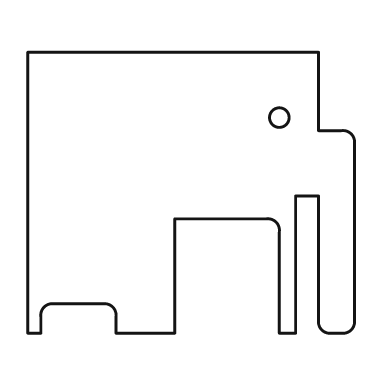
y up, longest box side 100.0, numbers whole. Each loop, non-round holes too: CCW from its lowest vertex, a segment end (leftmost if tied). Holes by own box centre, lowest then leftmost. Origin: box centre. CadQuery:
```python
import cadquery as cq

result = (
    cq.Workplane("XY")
    .moveTo(-50.0, -43.0)
    .lineTo(-46.0, -43.0)
    .lineTo(-46.0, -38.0)
    .threePointArc((-45.0, -35.0), (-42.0, -34.0))
    .lineTo(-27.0, -34.0)
    .threePointArc((-24.0, -35.0), (-23.0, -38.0))
    .lineTo(-23.0, -43.0)
    .lineTo(-5.0, -43.0)
    .lineTo(-5.0, -8.0)
    .lineTo(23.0, -8.0)
    .threePointArc((26.0, -9.0), (27.0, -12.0))
    .lineTo(27.0, -43.0)
    .lineTo(32.0, -43.0)
    .lineTo(32.0, -1.0)
    .lineTo(39.0, -1.0)
    .lineTo(39.0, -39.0)
    .threePointArc((40.0, -42.0), (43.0, -43.0))
    .lineTo(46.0, -43.0)
    .threePointArc((49.0, -42.0), (50.0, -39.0))
    .lineTo(50.0, 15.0)
    .threePointArc((49.0, 18.0), (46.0, 19.0))
    .lineTo(39.0, 19.0)
    .lineTo(39.0, 43.0)
    .lineTo(-50.0, 43.0)
    .close()
    .moveTo(27.0, 23.0)
    .circle(3.0)
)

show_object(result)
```